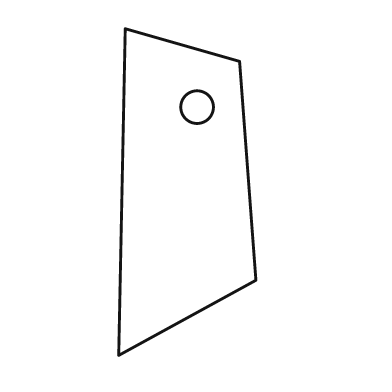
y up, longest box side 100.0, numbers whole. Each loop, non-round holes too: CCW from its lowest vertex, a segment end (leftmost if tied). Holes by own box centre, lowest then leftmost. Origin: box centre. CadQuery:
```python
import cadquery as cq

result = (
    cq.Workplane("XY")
    .moveTo(-21.0, -50.0)
    .lineTo(21.0, -27.0)
    .lineTo(16.0, 40.0)
    .lineTo(-19.0, 50.0)
    .close()
    .moveTo(3.0, 26.0)
    .circle(5.0)
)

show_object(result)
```